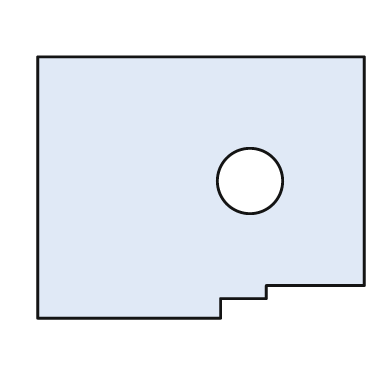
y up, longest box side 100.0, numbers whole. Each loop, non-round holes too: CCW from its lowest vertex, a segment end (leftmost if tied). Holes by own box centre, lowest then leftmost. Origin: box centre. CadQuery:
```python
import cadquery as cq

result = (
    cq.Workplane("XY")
    .moveTo(-50.0, -40.0)
    .lineTo(6.0, -40.0)
    .lineTo(6.0, -34.0)
    .lineTo(20.0, -34.0)
    .lineTo(20.0, -30.0)
    .lineTo(50.0, -30.0)
    .lineTo(50.0, 40.0)
    .lineTo(-50.0, 40.0)
    .close()
    .moveTo(15.0, 2.0)
    .circle(10.0)
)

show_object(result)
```